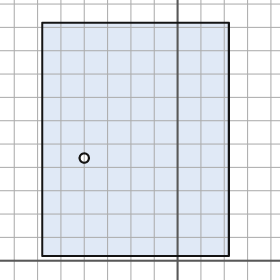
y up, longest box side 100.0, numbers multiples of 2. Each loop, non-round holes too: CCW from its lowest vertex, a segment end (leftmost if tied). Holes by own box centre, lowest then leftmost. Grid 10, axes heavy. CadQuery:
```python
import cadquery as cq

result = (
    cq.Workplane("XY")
    .moveTo(-58.0, 2.0)
    .lineTo(22.0, 2.0)
    .lineTo(22.0, 102.0)
    .lineTo(-58.0, 102.0)
    .close()
    .moveTo(-40.0, 44.0)
    .circle(2.0)
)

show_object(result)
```